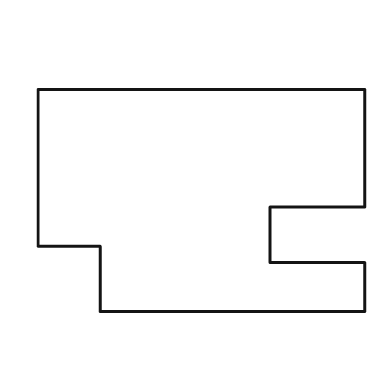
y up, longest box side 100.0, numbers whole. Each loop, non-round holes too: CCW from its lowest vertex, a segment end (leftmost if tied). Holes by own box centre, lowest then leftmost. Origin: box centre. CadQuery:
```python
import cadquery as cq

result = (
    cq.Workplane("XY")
    .moveTo(-31.0, -34.0)
    .lineTo(50.0, -34.0)
    .lineTo(50.0, -19.0)
    .lineTo(21.0, -19.0)
    .lineTo(21.0, -2.0)
    .lineTo(50.0, -2.0)
    .lineTo(50.0, 34.0)
    .lineTo(-50.0, 34.0)
    .lineTo(-50.0, -14.0)
    .lineTo(-31.0, -14.0)
    .close()
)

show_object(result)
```